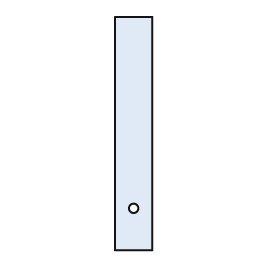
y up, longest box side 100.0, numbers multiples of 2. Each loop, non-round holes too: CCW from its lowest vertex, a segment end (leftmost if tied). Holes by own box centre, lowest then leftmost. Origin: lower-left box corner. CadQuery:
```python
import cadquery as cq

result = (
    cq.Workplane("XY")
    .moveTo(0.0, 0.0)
    .lineTo(16.0, 0.0)
    .lineTo(16.0, 100.0)
    .lineTo(0.0, 100.0)
    .close()
    .moveTo(8.0, 18.0)
    .circle(2.0)
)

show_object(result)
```